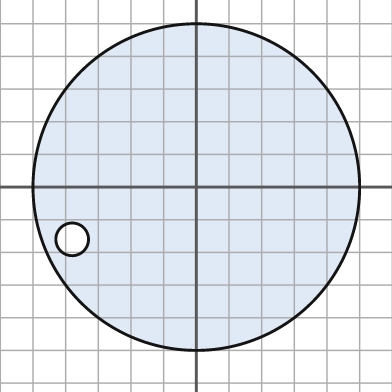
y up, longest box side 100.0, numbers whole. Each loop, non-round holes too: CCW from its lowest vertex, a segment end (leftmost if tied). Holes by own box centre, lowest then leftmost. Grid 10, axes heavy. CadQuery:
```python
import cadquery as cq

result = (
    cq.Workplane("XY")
    .moveTo(0.0, 0.0)
    .circle(50.0)
    .moveTo(-38.0, -16.0)
    .circle(5.0)
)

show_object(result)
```